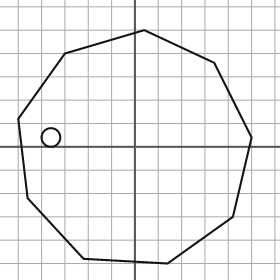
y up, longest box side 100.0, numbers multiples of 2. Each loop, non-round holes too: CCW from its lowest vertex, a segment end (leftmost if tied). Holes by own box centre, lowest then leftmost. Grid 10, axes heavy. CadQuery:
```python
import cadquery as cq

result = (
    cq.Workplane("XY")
    .moveTo(14.0, -50.0)
    .lineTo(42.0, -30.0)
    .lineTo(50.0, 4.0)
    .lineTo(34.0, 36.0)
    .lineTo(4.0, 50.0)
    .lineTo(-30.0, 40.0)
    .lineTo(-50.0, 12.0)
    .lineTo(-46.0, -22.0)
    .lineTo(-22.0, -48.0)
    .close()
    .moveTo(-36.0, 4.0)
    .circle(4.0)
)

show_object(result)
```